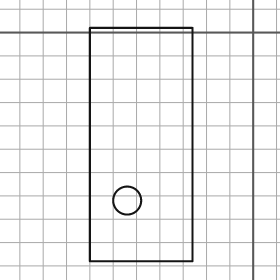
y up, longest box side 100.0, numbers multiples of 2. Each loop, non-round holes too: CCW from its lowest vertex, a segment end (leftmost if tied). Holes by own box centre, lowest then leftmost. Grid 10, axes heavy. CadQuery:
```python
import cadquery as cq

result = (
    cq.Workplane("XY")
    .moveTo(-70.0, -98.0)
    .lineTo(-26.0, -98.0)
    .lineTo(-26.0, 2.0)
    .lineTo(-70.0, 2.0)
    .close()
    .moveTo(-54.0, -72.0)
    .circle(6.0)
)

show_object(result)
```